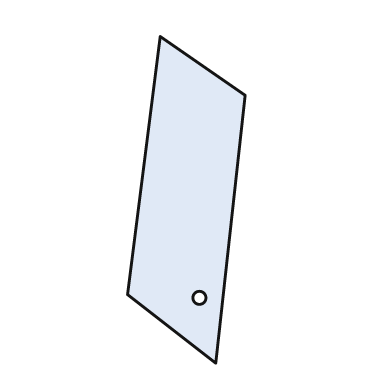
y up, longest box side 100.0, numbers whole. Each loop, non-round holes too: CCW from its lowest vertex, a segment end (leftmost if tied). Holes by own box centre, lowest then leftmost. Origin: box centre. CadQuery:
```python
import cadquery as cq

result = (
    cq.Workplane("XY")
    .moveTo(9.0, -50.0)
    .lineTo(18.0, 32.0)
    .lineTo(-8.0, 50.0)
    .lineTo(-18.0, -29.0)
    .close()
    .moveTo(4.0, -30.0)
    .circle(2.0)
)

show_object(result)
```